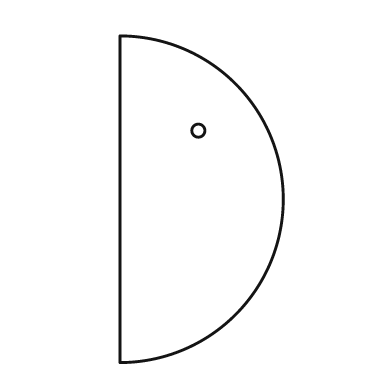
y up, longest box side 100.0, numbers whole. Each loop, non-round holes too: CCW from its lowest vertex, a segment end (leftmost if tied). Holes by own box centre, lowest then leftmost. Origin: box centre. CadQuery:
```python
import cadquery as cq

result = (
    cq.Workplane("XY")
    .moveTo(-25.0, -50.0)
    .threePointArc((25.0, 0.0), (-25.0, 50.0))
    .close()
    .moveTo(-1.0, 21.0)
    .circle(2.0)
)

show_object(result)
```